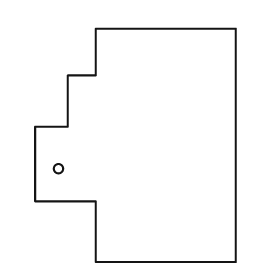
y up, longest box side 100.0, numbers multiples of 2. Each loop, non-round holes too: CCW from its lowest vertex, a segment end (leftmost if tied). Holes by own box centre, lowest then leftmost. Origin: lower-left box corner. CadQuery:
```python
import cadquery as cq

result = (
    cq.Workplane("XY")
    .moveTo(26.0, 0.0)
    .lineTo(86.0, 0.0)
    .lineTo(86.0, 100.0)
    .lineTo(26.0, 100.0)
    .lineTo(26.0, 80.0)
    .lineTo(14.0, 80.0)
    .lineTo(14.0, 58.0)
    .lineTo(0.0, 58.0)
    .lineTo(0.0, 26.0)
    .lineTo(26.0, 26.0)
    .close()
    .moveTo(10.0, 40.0)
    .circle(2.0)
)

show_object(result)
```